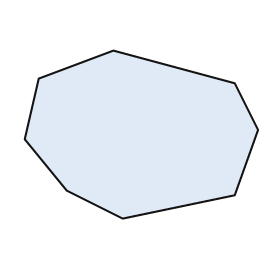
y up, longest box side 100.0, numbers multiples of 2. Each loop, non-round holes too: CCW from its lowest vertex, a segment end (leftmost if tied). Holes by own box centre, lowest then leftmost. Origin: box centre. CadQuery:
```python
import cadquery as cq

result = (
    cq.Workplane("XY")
    .moveTo(-8.0, -36.0)
    .lineTo(40.0, -26.0)
    .lineTo(50.0, 2.0)
    .lineTo(40.0, 22.0)
    .lineTo(-12.0, 36.0)
    .lineTo(-44.0, 24.0)
    .lineTo(-50.0, -2.0)
    .lineTo(-32.0, -24.0)
    .close()
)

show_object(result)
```